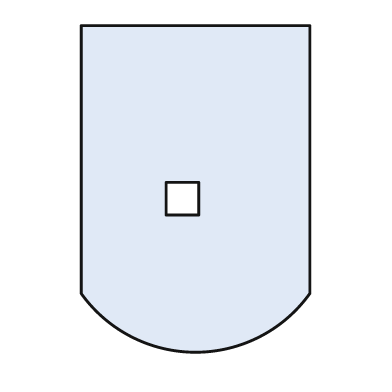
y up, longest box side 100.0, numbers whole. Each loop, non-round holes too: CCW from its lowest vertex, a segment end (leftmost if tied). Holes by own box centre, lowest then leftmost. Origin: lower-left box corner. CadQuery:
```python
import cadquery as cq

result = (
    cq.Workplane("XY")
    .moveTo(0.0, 18.0)
    .threePointArc((35.0, 0.0), (70.0, 18.0))
    .lineTo(70.0, 100.0)
    .lineTo(0.0, 100.0)
    .close()
    .moveTo(26.0, 42.0)
    .lineTo(36.0, 42.0)
    .lineTo(36.0, 52.0)
    .lineTo(26.0, 52.0)
    .close()
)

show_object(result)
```